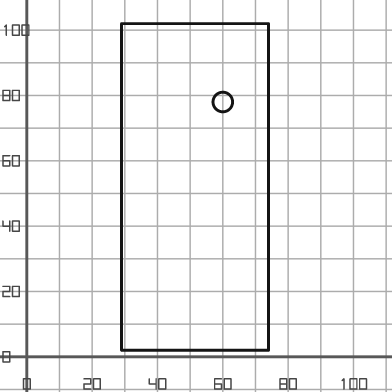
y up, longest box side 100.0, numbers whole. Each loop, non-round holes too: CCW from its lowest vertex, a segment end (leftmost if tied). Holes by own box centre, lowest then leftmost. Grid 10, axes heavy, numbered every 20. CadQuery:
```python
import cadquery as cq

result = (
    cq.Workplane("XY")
    .moveTo(29.0, 2.0)
    .lineTo(74.0, 2.0)
    .lineTo(74.0, 102.0)
    .lineTo(29.0, 102.0)
    .close()
    .moveTo(60.0, 78.0)
    .circle(3.0)
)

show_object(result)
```